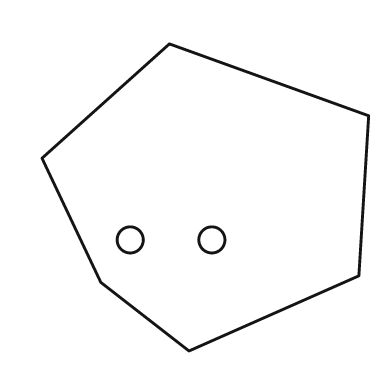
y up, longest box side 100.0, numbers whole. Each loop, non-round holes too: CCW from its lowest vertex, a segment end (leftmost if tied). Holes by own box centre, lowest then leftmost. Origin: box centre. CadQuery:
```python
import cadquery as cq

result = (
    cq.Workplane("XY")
    .moveTo(-5.0, -47.0)
    .lineTo(47.0, -24.0)
    .lineTo(50.0, 25.0)
    .lineTo(-11.0, 47.0)
    .lineTo(-50.0, 12.0)
    .lineTo(-32.0, -26.0)
    .close()
    .moveTo(-23.0, -13.0)
    .circle(4.0)
    .moveTo(2.0, -13.0)
    .circle(4.0)
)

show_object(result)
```